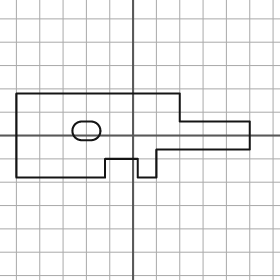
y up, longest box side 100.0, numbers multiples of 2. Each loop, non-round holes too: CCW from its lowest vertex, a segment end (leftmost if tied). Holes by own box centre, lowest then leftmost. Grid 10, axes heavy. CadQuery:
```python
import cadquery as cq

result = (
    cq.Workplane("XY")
    .moveTo(-50.0, -18.0)
    .lineTo(-12.0, -18.0)
    .lineTo(-12.0, -10.0)
    .lineTo(2.0, -10.0)
    .lineTo(2.0, -18.0)
    .lineTo(10.0, -18.0)
    .lineTo(10.0, -6.0)
    .lineTo(50.0, -6.0)
    .lineTo(50.0, 6.0)
    .lineTo(20.0, 6.0)
    .lineTo(20.0, 18.0)
    .lineTo(-50.0, 18.0)
    .close()
    .moveTo(-22.0, -2.0)
    .lineTo(-18.0, -2.0)
    .threePointArc((-14.0, 2.0), (-18.0, 6.0))
    .lineTo(-22.0, 6.0)
    .threePointArc((-26.0, 2.0), (-22.0, -2.0))
    .close()
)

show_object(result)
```